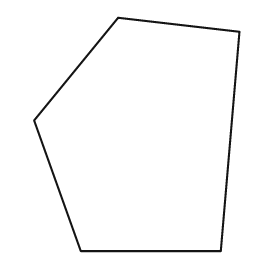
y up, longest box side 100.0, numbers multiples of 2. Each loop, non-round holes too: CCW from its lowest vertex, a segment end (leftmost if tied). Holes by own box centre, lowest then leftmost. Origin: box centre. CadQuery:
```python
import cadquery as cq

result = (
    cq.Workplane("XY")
    .moveTo(-24.0, -50.0)
    .lineTo(36.0, -50.0)
    .lineTo(44.0, 44.0)
    .lineTo(-8.0, 50.0)
    .lineTo(-44.0, 6.0)
    .close()
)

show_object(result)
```